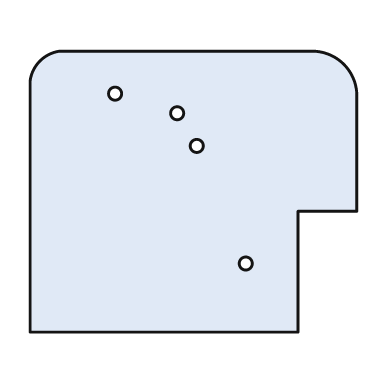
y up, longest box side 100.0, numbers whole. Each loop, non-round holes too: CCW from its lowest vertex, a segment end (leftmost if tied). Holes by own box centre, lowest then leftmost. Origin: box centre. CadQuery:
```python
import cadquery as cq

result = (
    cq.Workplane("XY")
    .moveTo(-50.0, -43.0)
    .lineTo(32.0, -43.0)
    .lineTo(32.0, -6.0)
    .lineTo(50.0, -6.0)
    .lineTo(50.0, 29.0)
    .threePointArc((46.0, 39.0), (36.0, 43.0))
    .lineTo(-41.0, 43.0)
    .threePointArc((-47.0, 40.0), (-50.0, 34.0))
    .close()
    .moveTo(16.0, -22.0)
    .circle(2.0)
    .moveTo(1.0, 14.0)
    .circle(2.0)
    .moveTo(-5.0, 24.0)
    .circle(2.0)
    .moveTo(-24.0, 30.0)
    .circle(2.0)
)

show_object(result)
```